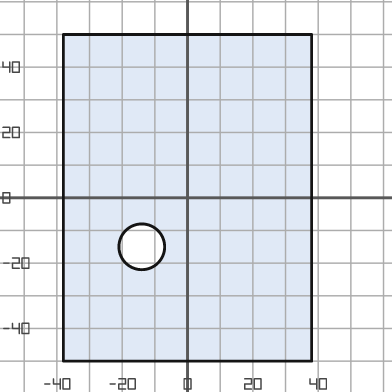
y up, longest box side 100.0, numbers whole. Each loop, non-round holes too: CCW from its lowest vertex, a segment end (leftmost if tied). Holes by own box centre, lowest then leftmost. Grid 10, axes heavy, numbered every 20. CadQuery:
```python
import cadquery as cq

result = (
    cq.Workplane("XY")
    .moveTo(-38.0, -50.0)
    .lineTo(38.0, -50.0)
    .lineTo(38.0, 50.0)
    .lineTo(-38.0, 50.0)
    .close()
    .moveTo(-14.0, -15.0)
    .circle(7.0)
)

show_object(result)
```